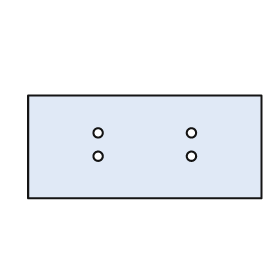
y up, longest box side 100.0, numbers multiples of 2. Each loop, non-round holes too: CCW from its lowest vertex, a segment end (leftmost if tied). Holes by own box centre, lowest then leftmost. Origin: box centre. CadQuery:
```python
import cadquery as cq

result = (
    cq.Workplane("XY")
    .moveTo(-50.0, -22.0)
    .lineTo(50.0, -22.0)
    .lineTo(50.0, 22.0)
    .lineTo(-50.0, 22.0)
    .close()
    .moveTo(-20.0, -4.0)
    .circle(2.0)
    .moveTo(20.0, -4.0)
    .circle(2.0)
    .moveTo(-20.0, 6.0)
    .circle(2.0)
    .moveTo(20.0, 6.0)
    .circle(2.0)
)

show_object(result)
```